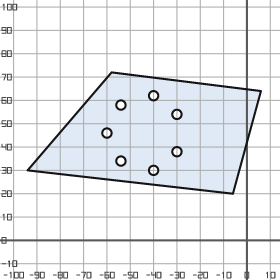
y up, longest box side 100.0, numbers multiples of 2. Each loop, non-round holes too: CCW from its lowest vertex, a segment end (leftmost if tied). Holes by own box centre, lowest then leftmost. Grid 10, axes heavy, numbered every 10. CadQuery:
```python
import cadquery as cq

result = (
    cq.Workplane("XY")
    .moveTo(-6.0, 20.0)
    .lineTo(6.0, 64.0)
    .lineTo(-58.0, 72.0)
    .lineTo(-94.0, 30.0)
    .close()
    .moveTo(-40.0, 30.0)
    .circle(2.0)
    .moveTo(-54.0, 34.0)
    .circle(2.0)
    .moveTo(-30.0, 38.0)
    .circle(2.0)
    .moveTo(-60.0, 46.0)
    .circle(2.0)
    .moveTo(-30.0, 54.0)
    .circle(2.0)
    .moveTo(-54.0, 58.0)
    .circle(2.0)
    .moveTo(-40.0, 62.0)
    .circle(2.0)
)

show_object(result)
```